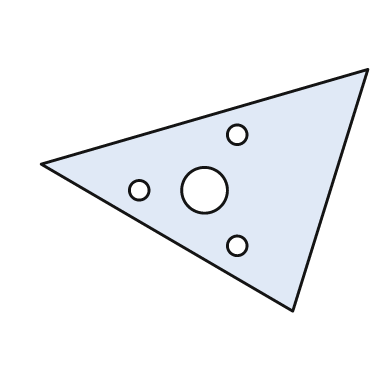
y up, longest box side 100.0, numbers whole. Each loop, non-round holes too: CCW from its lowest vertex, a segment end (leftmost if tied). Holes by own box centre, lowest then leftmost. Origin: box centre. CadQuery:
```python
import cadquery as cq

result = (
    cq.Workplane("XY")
    .moveTo(27.0, -37.0)
    .lineTo(50.0, 37.0)
    .lineTo(-50.0, 8.0)
    .close()
    .moveTo(10.0, -17.0)
    .circle(3.0)
    .moveTo(-20.0, 0.0)
    .circle(3.0)
    .moveTo(0.0, 0.0)
    .circle(7.0)
    .moveTo(10.0, 17.0)
    .circle(3.0)
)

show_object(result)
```